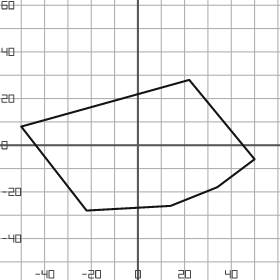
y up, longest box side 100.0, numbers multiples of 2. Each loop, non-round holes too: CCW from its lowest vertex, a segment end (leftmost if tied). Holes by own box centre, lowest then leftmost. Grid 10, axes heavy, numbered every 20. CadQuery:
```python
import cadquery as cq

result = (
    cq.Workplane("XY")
    .moveTo(-22.0, -28.0)
    .lineTo(14.0, -26.0)
    .lineTo(34.0, -18.0)
    .lineTo(50.0, -6.0)
    .lineTo(22.0, 28.0)
    .lineTo(-50.0, 8.0)
    .close()
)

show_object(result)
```